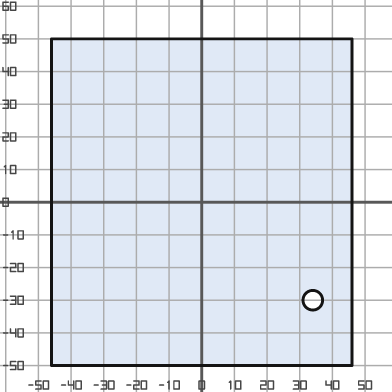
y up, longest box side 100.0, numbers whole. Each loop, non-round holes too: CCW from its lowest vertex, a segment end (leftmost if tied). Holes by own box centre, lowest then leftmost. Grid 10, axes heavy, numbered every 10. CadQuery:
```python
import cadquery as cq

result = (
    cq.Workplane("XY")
    .moveTo(-46.0, -50.0)
    .lineTo(46.0, -50.0)
    .lineTo(46.0, 50.0)
    .lineTo(-46.0, 50.0)
    .close()
    .moveTo(34.0, -30.0)
    .circle(3.0)
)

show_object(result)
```